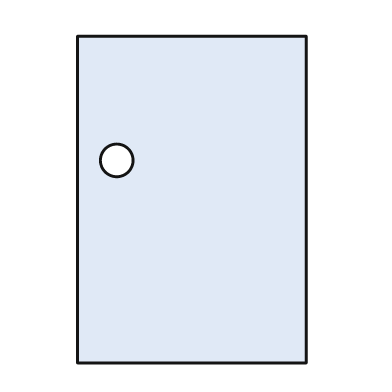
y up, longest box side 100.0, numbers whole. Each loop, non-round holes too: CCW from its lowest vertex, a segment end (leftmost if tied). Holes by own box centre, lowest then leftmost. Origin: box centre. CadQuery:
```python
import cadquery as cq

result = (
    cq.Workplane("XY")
    .moveTo(-35.0, -50.0)
    .lineTo(35.0, -50.0)
    .lineTo(35.0, 50.0)
    .lineTo(-35.0, 50.0)
    .close()
    .moveTo(-23.0, 12.0)
    .circle(5.0)
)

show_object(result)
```